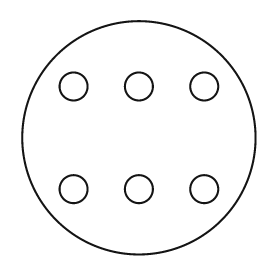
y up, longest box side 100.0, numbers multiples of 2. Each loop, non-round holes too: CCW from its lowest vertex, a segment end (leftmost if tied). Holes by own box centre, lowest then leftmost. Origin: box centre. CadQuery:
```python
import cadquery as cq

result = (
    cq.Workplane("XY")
    .moveTo(0.0, 0.0)
    .circle(50.0)
    .moveTo(-28.0, -22.0)
    .circle(6.0)
    .moveTo(0.0, -22.0)
    .circle(6.0)
    .moveTo(28.0, -22.0)
    .circle(6.0)
    .moveTo(-28.0, 22.0)
    .circle(6.0)
    .moveTo(0.0, 22.0)
    .circle(6.0)
    .moveTo(28.0, 22.0)
    .circle(6.0)
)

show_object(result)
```